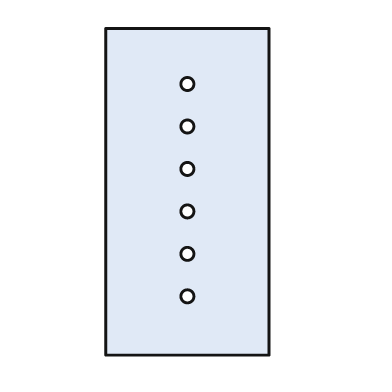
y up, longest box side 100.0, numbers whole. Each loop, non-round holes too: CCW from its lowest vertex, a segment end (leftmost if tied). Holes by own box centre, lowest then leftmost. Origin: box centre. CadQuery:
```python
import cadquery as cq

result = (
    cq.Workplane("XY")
    .moveTo(-25.0, -50.0)
    .lineTo(25.0, -50.0)
    .lineTo(25.0, 50.0)
    .lineTo(-25.0, 50.0)
    .close()
    .moveTo(0.0, -32.0)
    .circle(2.0)
    .moveTo(0.0, -19.0)
    .circle(2.0)
    .moveTo(0.0, -6.0)
    .circle(2.0)
    .moveTo(0.0, 7.0)
    .circle(2.0)
    .moveTo(0.0, 20.0)
    .circle(2.0)
    .moveTo(0.0, 33.0)
    .circle(2.0)
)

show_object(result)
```